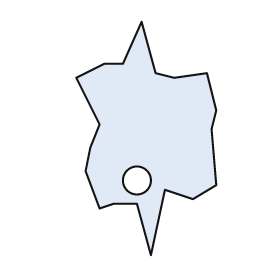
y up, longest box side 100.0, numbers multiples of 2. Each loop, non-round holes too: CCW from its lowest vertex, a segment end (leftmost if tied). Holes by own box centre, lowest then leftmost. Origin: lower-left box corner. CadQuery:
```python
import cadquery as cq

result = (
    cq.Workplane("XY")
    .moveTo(32.0, 0.0)
    .lineTo(38.0, 28.0)
    .lineTo(50.0, 24.0)
    .lineTo(60.0, 30.0)
    .lineTo(58.0, 54.0)
    .lineTo(60.0, 62.0)
    .lineTo(56.0, 78.0)
    .lineTo(42.0, 76.0)
    .lineTo(34.0, 78.0)
    .lineTo(28.0, 100.0)
    .lineTo(20.0, 82.0)
    .lineTo(12.0, 82.0)
    .lineTo(0.0, 76.0)
    .lineTo(10.0, 56.0)
    .lineTo(6.0, 46.0)
    .lineTo(4.0, 36.0)
    .lineTo(10.0, 20.0)
    .lineTo(16.0, 22.0)
    .lineTo(26.0, 22.0)
    .close()
    .moveTo(26.0, 32.0)
    .circle(6.0)
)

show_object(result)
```